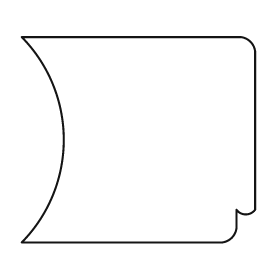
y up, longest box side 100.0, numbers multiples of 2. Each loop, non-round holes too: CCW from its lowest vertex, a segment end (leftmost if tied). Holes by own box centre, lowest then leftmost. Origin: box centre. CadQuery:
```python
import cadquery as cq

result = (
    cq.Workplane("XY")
    .moveTo(-50.0, -44.0)
    .lineTo(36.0, -44.0)
    .threePointArc((40.0, -42.0), (42.0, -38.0))
    .lineTo(42.0, -30.0)
    .threePointArc((46.0, -32.0), (50.0, -30.0))
    .lineTo(50.0, 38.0)
    .threePointArc((48.0, 42.0), (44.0, 44.0))
    .lineTo(-50.0, 44.0)
    .threePointArc((-32.0, 0.0), (-50.0, -44.0))
    .close()
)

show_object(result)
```